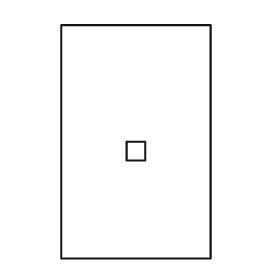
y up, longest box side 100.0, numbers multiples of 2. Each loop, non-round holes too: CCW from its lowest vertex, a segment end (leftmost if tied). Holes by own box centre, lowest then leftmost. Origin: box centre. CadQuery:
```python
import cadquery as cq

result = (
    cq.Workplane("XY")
    .moveTo(-32.0, -50.0)
    .lineTo(32.0, -50.0)
    .lineTo(32.0, 50.0)
    .lineTo(-32.0, 50.0)
    .close()
    .moveTo(-4.0, -8.0)
    .lineTo(4.0, -8.0)
    .lineTo(4.0, 0.0)
    .lineTo(-4.0, 0.0)
    .close()
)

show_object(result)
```